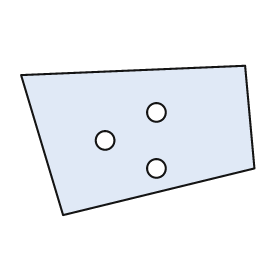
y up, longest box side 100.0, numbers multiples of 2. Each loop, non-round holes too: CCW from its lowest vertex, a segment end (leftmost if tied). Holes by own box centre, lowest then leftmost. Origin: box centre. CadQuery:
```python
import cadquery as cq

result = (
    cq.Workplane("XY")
    .moveTo(-32.0, -32.0)
    .lineTo(50.0, -12.0)
    .lineTo(46.0, 32.0)
    .lineTo(-50.0, 28.0)
    .close()
    .moveTo(8.0, -12.0)
    .circle(4.0)
    .moveTo(-14.0, 0.0)
    .circle(4.0)
    .moveTo(8.0, 12.0)
    .circle(4.0)
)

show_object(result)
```